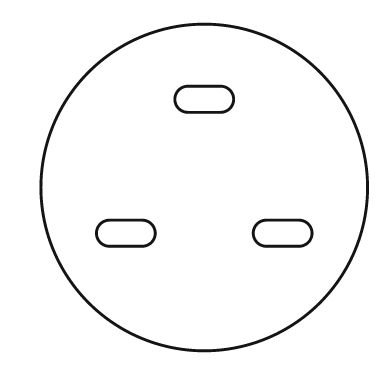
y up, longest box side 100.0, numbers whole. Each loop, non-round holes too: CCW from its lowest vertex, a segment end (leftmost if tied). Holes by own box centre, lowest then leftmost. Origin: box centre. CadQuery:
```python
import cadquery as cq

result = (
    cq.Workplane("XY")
    .moveTo(0.0, 0.0)
    .circle(50.0)
    .moveTo(-29.0, -18.0)
    .lineTo(-19.0, -18.0)
    .threePointArc((-15.0, -14.0), (-19.0, -10.0))
    .lineTo(-29.0, -10.0)
    .threePointArc((-33.0, -14.0), (-29.0, -18.0))
    .close()
    .moveTo(19.0, -18.0)
    .lineTo(29.0, -18.0)
    .threePointArc((33.0, -14.0), (29.0, -10.0))
    .lineTo(19.0, -10.0)
    .threePointArc((15.0, -14.0), (19.0, -18.0))
    .close()
    .moveTo(-5.0, 23.0)
    .lineTo(5.0, 23.0)
    .threePointArc((9.0, 27.0), (5.0, 31.0))
    .lineTo(-5.0, 31.0)
    .threePointArc((-9.0, 27.0), (-5.0, 23.0))
    .close()
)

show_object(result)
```